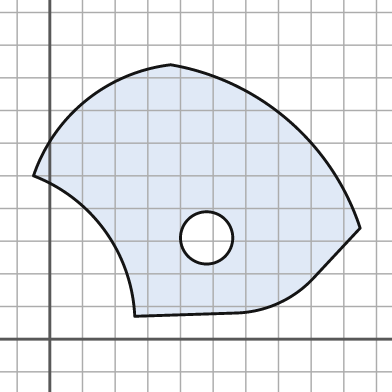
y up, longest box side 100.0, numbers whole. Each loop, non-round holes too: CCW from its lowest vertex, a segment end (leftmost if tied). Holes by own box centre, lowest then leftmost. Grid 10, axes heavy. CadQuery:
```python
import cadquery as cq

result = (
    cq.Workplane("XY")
    .moveTo(26.0, 7.0)
    .lineTo(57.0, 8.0)
    .threePointArc((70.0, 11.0), (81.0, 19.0))
    .lineTo(95.0, 34.0)
    .threePointArc((73.0, 67.0), (37.0, 84.0))
    .threePointArc((11.0, 73.0), (-5.0, 50.0))
    .threePointArc((17.0, 33.0), (26.0, 7.0))
    .close()
    .moveTo(48.0, 31.0)
    .circle(8.0)
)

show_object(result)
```